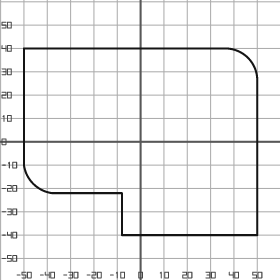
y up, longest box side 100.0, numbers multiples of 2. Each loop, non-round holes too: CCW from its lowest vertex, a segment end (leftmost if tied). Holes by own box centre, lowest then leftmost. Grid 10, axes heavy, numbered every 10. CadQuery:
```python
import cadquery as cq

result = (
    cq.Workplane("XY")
    .moveTo(-8.0, -40.0)
    .lineTo(50.0, -40.0)
    .lineTo(50.0, 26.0)
    .threePointArc((46.0, 36.0), (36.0, 40.0))
    .lineTo(-50.0, 40.0)
    .lineTo(-50.0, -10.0)
    .threePointArc((-46.0, -18.0), (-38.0, -22.0))
    .lineTo(-8.0, -22.0)
    .close()
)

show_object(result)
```